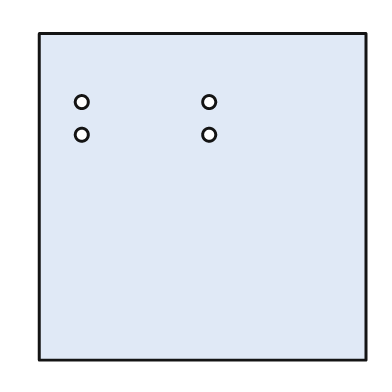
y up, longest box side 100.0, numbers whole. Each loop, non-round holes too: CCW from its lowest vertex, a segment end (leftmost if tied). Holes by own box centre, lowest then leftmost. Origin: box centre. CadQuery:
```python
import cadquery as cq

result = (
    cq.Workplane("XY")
    .moveTo(-50.0, -50.0)
    .lineTo(50.0, -50.0)
    .lineTo(50.0, 50.0)
    .lineTo(-50.0, 50.0)
    .close()
    .moveTo(-37.0, 19.0)
    .circle(2.0)
    .moveTo(2.0, 19.0)
    .circle(2.0)
    .moveTo(-37.0, 29.0)
    .circle(2.0)
    .moveTo(2.0, 29.0)
    .circle(2.0)
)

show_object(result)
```